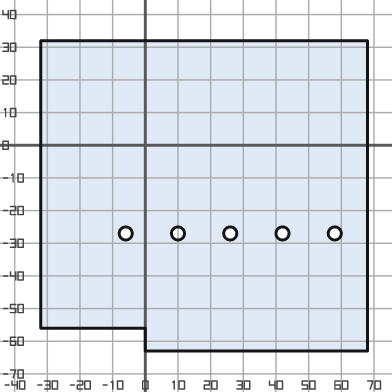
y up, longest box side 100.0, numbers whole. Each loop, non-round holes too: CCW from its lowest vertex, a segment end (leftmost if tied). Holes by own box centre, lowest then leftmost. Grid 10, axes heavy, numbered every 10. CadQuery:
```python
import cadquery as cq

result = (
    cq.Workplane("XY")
    .moveTo(0.0, -63.0)
    .lineTo(68.0, -63.0)
    .lineTo(68.0, 32.0)
    .lineTo(-32.0, 32.0)
    .lineTo(-32.0, -56.0)
    .lineTo(0.0, -56.0)
    .close()
    .moveTo(-6.0, -27.0)
    .circle(2.0)
    .moveTo(10.0, -27.0)
    .circle(2.0)
    .moveTo(26.0, -27.0)
    .circle(2.0)
    .moveTo(42.0, -27.0)
    .circle(2.0)
    .moveTo(58.0, -27.0)
    .circle(2.0)
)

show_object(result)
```